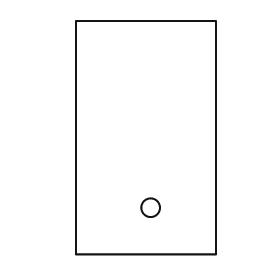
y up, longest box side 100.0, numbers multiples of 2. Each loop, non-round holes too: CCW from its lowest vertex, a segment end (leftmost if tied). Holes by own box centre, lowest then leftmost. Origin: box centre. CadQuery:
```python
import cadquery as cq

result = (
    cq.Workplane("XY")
    .moveTo(-30.0, -50.0)
    .lineTo(30.0, -50.0)
    .lineTo(30.0, 50.0)
    .lineTo(-30.0, 50.0)
    .close()
    .moveTo(2.0, -30.0)
    .circle(4.0)
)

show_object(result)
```